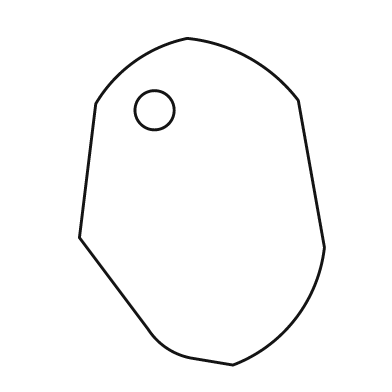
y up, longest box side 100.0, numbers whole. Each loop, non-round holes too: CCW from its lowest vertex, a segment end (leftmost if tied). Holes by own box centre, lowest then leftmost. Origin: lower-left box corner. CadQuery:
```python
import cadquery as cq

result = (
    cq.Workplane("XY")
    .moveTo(47.0, 0.0)
    .threePointArc((66.0, 14.0), (75.0, 36.0))
    .lineTo(67.0, 81.0)
    .threePointArc((52.0, 94.0), (33.0, 100.0))
    .threePointArc((17.0, 93.0), (5.0, 80.0))
    .lineTo(0.0, 39.0)
    .lineTo(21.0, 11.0)
    .threePointArc((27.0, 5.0), (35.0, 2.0))
    .close()
    .moveTo(23.0, 78.0)
    .circle(6.0)
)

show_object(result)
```